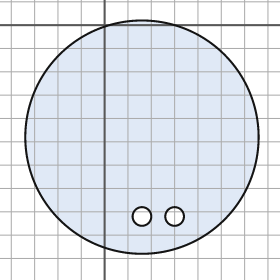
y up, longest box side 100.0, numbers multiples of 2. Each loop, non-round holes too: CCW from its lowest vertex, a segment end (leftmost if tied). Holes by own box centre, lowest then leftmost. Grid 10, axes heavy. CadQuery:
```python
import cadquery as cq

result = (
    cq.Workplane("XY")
    .moveTo(16.0, -48.0)
    .circle(50.0)
    .moveTo(16.0, -82.0)
    .circle(4.0)
    .moveTo(30.0, -82.0)
    .circle(4.0)
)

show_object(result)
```